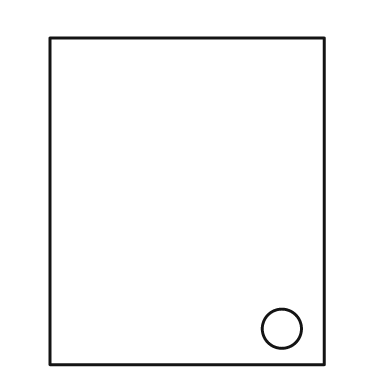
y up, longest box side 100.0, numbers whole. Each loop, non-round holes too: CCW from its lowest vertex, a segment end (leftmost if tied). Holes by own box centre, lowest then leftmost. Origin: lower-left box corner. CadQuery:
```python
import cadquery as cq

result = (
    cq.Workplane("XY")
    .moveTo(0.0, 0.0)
    .lineTo(84.0, 0.0)
    .lineTo(84.0, 100.0)
    .lineTo(0.0, 100.0)
    .close()
    .moveTo(71.0, 11.0)
    .circle(6.0)
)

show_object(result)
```